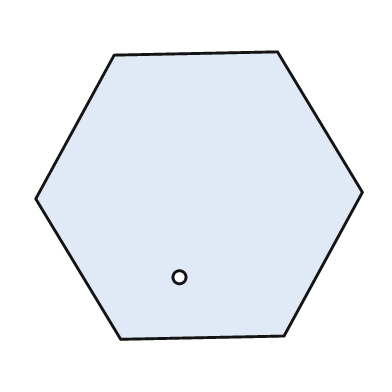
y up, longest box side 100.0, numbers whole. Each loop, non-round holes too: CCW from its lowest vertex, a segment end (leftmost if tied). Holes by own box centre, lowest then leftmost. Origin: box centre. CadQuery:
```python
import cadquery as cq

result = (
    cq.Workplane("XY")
    .moveTo(-24.0, -44.0)
    .lineTo(26.0, -43.0)
    .lineTo(50.0, 1.0)
    .lineTo(24.0, 44.0)
    .lineTo(-26.0, 43.0)
    .lineTo(-50.0, -1.0)
    .close()
    .moveTo(-6.0, -25.0)
    .circle(2.0)
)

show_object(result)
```